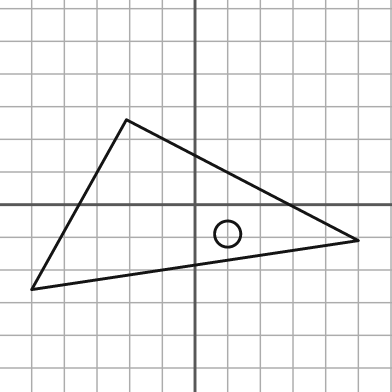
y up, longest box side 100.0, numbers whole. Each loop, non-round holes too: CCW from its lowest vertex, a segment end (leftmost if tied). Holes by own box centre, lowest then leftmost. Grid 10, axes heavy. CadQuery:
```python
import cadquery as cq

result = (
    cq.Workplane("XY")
    .moveTo(-50.0, -26.0)
    .lineTo(50.0, -11.0)
    .lineTo(-21.0, 26.0)
    .close()
    .moveTo(10.0, -9.0)
    .circle(4.0)
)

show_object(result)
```